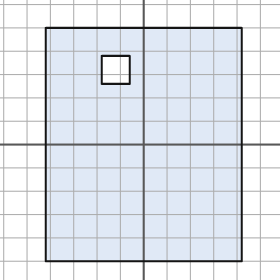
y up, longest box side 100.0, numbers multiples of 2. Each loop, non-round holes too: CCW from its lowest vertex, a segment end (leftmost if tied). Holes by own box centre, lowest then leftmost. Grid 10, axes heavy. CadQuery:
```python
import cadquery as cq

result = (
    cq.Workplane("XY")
    .moveTo(-42.0, -50.0)
    .lineTo(42.0, -50.0)
    .lineTo(42.0, 50.0)
    .lineTo(-42.0, 50.0)
    .close()
    .moveTo(-18.0, 26.0)
    .lineTo(-6.0, 26.0)
    .lineTo(-6.0, 38.0)
    .lineTo(-18.0, 38.0)
    .close()
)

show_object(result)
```